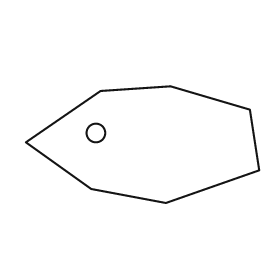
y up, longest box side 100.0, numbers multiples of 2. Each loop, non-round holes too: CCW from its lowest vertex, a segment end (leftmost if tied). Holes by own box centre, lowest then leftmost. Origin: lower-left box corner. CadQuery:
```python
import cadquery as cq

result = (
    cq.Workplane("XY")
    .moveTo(60.0, 0.0)
    .lineTo(100.0, 14.0)
    .lineTo(96.0, 40.0)
    .lineTo(62.0, 50.0)
    .lineTo(32.0, 48.0)
    .lineTo(0.0, 26.0)
    .lineTo(28.0, 6.0)
    .close()
    .moveTo(30.0, 30.0)
    .circle(4.0)
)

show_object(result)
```